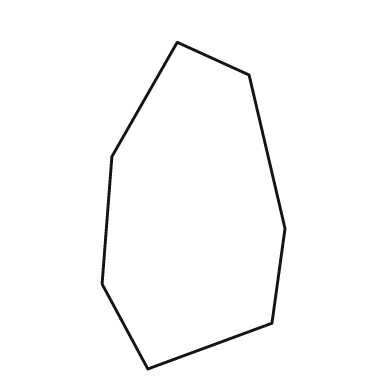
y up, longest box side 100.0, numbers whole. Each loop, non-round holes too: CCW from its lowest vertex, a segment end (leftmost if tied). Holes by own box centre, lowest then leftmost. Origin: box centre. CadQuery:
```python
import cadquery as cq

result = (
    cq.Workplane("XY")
    .moveTo(-14.0, -50.0)
    .lineTo(24.0, -36.0)
    .lineTo(28.0, -7.0)
    .lineTo(17.0, 40.0)
    .lineTo(-5.0, 50.0)
    .lineTo(-25.0, 15.0)
    .lineTo(-28.0, -24.0)
    .close()
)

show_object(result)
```